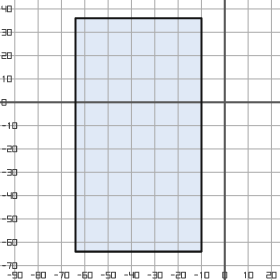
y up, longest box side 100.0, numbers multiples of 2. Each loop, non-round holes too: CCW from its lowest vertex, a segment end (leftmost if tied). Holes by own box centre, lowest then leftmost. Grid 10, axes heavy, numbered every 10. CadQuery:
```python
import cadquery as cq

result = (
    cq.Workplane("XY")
    .moveTo(-64.0, -64.0)
    .lineTo(-10.0, -64.0)
    .lineTo(-10.0, 36.0)
    .lineTo(-64.0, 36.0)
    .close()
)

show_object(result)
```